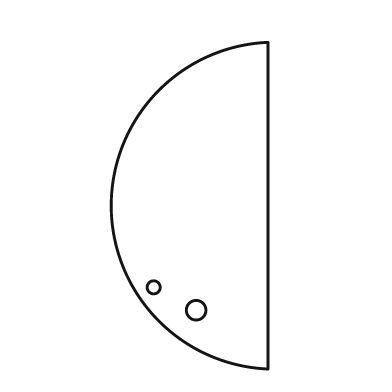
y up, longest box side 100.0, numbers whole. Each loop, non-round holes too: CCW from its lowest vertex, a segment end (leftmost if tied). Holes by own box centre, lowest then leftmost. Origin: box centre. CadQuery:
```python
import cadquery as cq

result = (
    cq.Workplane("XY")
    .moveTo(24.0, -50.0)
    .lineTo(24.0, 50.0)
    .threePointArc((-24.0, 0.0), (24.0, -50.0))
    .close()
    .moveTo(2.0, -32.0)
    .circle(3.0)
    .moveTo(-11.0, -25.0)
    .circle(2.0)
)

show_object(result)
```